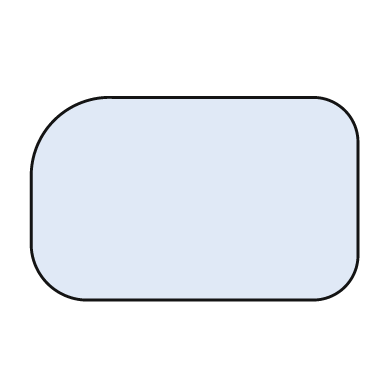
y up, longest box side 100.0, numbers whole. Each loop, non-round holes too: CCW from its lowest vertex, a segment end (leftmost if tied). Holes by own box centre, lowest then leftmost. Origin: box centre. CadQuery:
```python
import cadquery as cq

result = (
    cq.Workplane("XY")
    .moveTo(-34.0, -31.0)
    .lineTo(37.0, -31.0)
    .threePointArc((46.0, -27.0), (50.0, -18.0))
    .lineTo(50.0, 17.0)
    .threePointArc((46.0, 27.0), (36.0, 31.0))
    .lineTo(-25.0, 31.0)
    .threePointArc((-43.0, 24.0), (-50.0, 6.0))
    .lineTo(-50.0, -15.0)
    .threePointArc((-45.0, -26.0), (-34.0, -31.0))
    .close()
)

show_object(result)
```